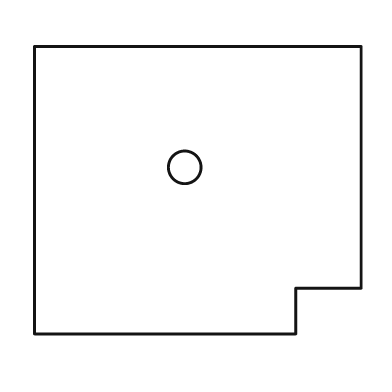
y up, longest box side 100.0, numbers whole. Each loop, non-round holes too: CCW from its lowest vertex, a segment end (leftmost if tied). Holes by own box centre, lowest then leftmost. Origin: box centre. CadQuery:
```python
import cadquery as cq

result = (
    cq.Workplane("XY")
    .moveTo(-50.0, -44.0)
    .lineTo(30.0, -44.0)
    .lineTo(30.0, -30.0)
    .lineTo(50.0, -30.0)
    .lineTo(50.0, 44.0)
    .lineTo(-50.0, 44.0)
    .close()
    .moveTo(-4.0, 7.0)
    .circle(5.0)
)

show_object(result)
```